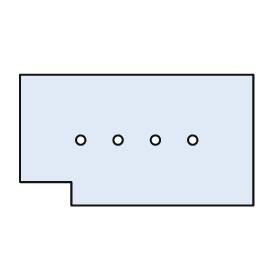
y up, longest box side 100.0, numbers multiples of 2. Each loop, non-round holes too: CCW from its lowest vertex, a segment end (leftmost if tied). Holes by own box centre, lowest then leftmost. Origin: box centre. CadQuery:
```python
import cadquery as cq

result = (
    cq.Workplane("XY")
    .moveTo(-28.0, -28.0)
    .lineTo(50.0, -28.0)
    .lineTo(50.0, 28.0)
    .lineTo(-50.0, 28.0)
    .lineTo(-50.0, -18.0)
    .lineTo(-28.0, -18.0)
    .close()
    .moveTo(-24.0, 0.0)
    .circle(2.0)
    .moveTo(-8.0, 0.0)
    .circle(2.0)
    .moveTo(8.0, 0.0)
    .circle(2.0)
    .moveTo(24.0, 0.0)
    .circle(2.0)
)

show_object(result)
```